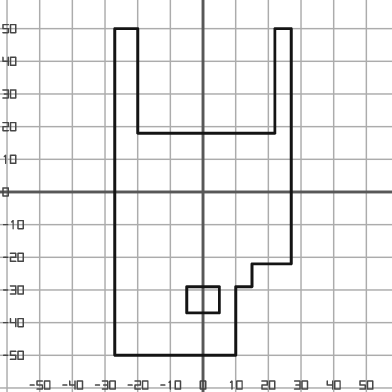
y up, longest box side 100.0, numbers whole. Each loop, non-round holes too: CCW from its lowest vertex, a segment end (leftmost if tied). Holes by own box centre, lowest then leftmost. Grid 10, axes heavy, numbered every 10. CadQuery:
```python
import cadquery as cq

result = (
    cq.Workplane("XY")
    .moveTo(-27.0, -50.0)
    .lineTo(10.0, -50.0)
    .lineTo(10.0, -29.0)
    .lineTo(15.0, -29.0)
    .lineTo(15.0, -22.0)
    .lineTo(27.0, -22.0)
    .lineTo(27.0, 50.0)
    .lineTo(22.0, 50.0)
    .lineTo(22.0, 18.0)
    .lineTo(-20.0, 18.0)
    .lineTo(-20.0, 50.0)
    .lineTo(-27.0, 50.0)
    .close()
    .moveTo(-5.0, -37.0)
    .lineTo(5.0, -37.0)
    .lineTo(5.0, -29.0)
    .lineTo(-5.0, -29.0)
    .close()
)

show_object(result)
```